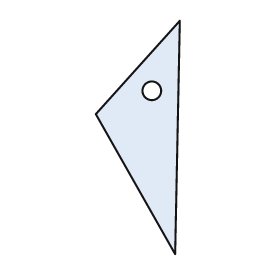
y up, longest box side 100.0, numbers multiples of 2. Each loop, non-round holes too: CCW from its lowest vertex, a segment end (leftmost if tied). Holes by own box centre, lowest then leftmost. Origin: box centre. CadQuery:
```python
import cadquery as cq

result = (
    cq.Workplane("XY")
    .moveTo(16.0, -50.0)
    .lineTo(18.0, 50.0)
    .lineTo(-18.0, 10.0)
    .close()
    .moveTo(6.0, 20.0)
    .circle(4.0)
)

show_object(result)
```